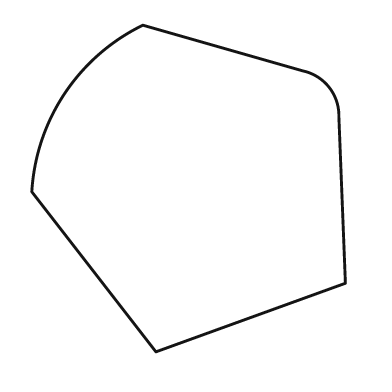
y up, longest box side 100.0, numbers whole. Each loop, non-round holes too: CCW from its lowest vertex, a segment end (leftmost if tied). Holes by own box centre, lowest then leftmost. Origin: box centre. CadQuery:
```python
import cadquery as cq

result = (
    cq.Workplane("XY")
    .moveTo(-10.0, -50.0)
    .lineTo(48.0, -29.0)
    .lineTo(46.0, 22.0)
    .threePointArc((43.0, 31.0), (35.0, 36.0))
    .lineTo(-14.0, 50.0)
    .threePointArc((-38.0, 29.0), (-48.0, -1.0))
    .close()
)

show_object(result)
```